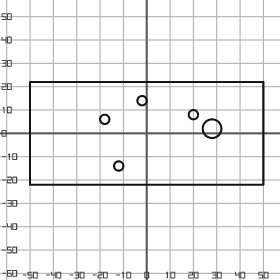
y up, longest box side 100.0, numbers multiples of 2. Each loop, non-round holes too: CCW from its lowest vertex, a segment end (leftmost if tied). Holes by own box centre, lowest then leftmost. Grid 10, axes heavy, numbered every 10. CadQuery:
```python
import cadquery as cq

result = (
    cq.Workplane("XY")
    .moveTo(-50.0, -22.0)
    .lineTo(50.0, -22.0)
    .lineTo(50.0, 22.0)
    .lineTo(-50.0, 22.0)
    .close()
    .moveTo(-12.0, -14.0)
    .circle(2.0)
    .moveTo(28.0, 2.0)
    .circle(4.0)
    .moveTo(-18.0, 6.0)
    .circle(2.0)
    .moveTo(20.0, 8.0)
    .circle(2.0)
    .moveTo(-2.0, 14.0)
    .circle(2.0)
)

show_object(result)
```